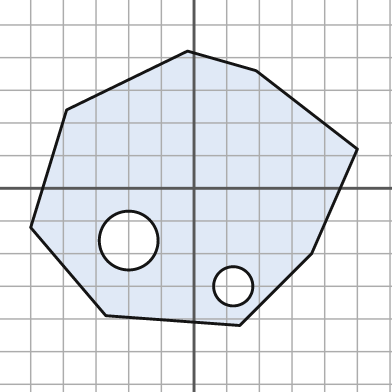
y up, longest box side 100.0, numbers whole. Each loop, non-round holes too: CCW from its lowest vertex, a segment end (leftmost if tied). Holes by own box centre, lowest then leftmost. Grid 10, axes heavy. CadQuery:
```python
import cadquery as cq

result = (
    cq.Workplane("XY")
    .moveTo(14.0, -42.0)
    .lineTo(36.0, -20.0)
    .lineTo(50.0, 12.0)
    .lineTo(19.0, 36.0)
    .lineTo(-2.0, 42.0)
    .lineTo(-39.0, 24.0)
    .lineTo(-50.0, -12.0)
    .lineTo(-27.0, -39.0)
    .close()
    .moveTo(12.0, -30.0)
    .circle(6.0)
    .moveTo(-20.0, -16.0)
    .circle(9.0)
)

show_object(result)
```